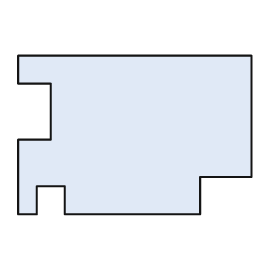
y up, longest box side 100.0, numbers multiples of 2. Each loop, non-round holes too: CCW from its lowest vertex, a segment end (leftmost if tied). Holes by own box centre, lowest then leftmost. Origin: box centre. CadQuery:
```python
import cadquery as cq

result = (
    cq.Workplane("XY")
    .moveTo(-50.0, -34.0)
    .lineTo(-42.0, -34.0)
    .lineTo(-42.0, -22.0)
    .lineTo(-30.0, -22.0)
    .lineTo(-30.0, -34.0)
    .lineTo(28.0, -34.0)
    .lineTo(28.0, -18.0)
    .lineTo(50.0, -18.0)
    .lineTo(50.0, 34.0)
    .lineTo(-50.0, 34.0)
    .lineTo(-50.0, 22.0)
    .lineTo(-36.0, 22.0)
    .lineTo(-36.0, -2.0)
    .lineTo(-50.0, -2.0)
    .close()
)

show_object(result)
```